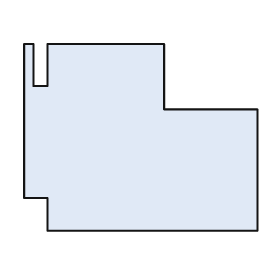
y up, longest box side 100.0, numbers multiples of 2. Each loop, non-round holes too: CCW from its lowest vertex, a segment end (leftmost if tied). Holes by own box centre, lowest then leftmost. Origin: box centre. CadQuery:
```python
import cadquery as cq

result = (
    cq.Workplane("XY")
    .moveTo(-40.0, -40.0)
    .lineTo(50.0, -40.0)
    .lineTo(50.0, 12.0)
    .lineTo(10.0, 12.0)
    .lineTo(10.0, 40.0)
    .lineTo(-40.0, 40.0)
    .lineTo(-40.0, 22.0)
    .lineTo(-46.0, 22.0)
    .lineTo(-46.0, 40.0)
    .lineTo(-50.0, 40.0)
    .lineTo(-50.0, -26.0)
    .lineTo(-40.0, -26.0)
    .close()
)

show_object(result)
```